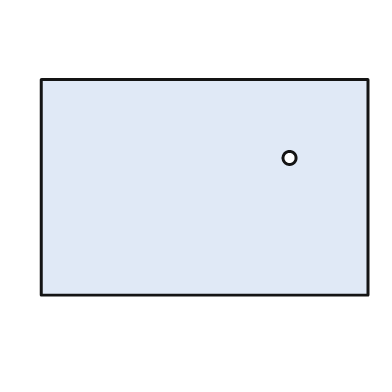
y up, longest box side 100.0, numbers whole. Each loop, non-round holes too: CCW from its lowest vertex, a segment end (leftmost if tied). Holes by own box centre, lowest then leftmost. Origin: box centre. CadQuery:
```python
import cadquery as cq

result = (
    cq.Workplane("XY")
    .moveTo(-50.0, -33.0)
    .lineTo(50.0, -33.0)
    .lineTo(50.0, 33.0)
    .lineTo(-50.0, 33.0)
    .close()
    .moveTo(26.0, 9.0)
    .circle(2.0)
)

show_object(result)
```